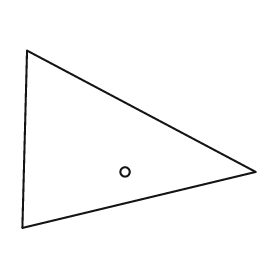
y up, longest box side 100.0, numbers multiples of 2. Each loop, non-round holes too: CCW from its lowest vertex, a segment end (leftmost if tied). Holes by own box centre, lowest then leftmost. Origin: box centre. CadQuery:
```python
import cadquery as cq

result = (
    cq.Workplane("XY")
    .moveTo(-50.0, -38.0)
    .lineTo(50.0, -14.0)
    .lineTo(-48.0, 38.0)
    .close()
    .moveTo(-6.0, -14.0)
    .circle(2.0)
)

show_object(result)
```